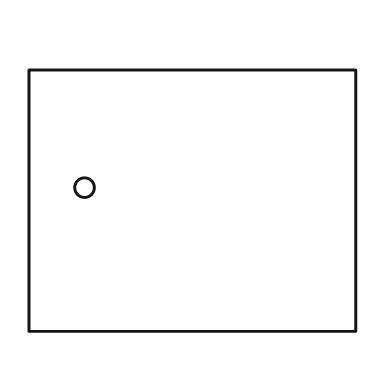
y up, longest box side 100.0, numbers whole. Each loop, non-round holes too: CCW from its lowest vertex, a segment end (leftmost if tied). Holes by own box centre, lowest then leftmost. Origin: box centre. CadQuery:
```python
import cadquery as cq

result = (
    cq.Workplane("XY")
    .moveTo(-50.0, -40.0)
    .lineTo(50.0, -40.0)
    .lineTo(50.0, 40.0)
    .lineTo(-50.0, 40.0)
    .close()
    .moveTo(-33.0, 4.0)
    .circle(3.0)
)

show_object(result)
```